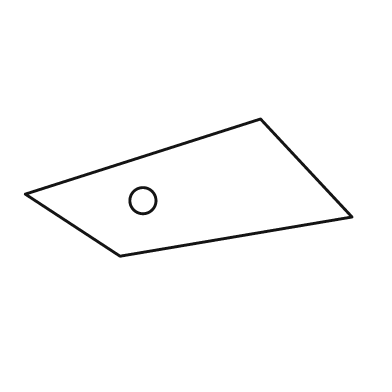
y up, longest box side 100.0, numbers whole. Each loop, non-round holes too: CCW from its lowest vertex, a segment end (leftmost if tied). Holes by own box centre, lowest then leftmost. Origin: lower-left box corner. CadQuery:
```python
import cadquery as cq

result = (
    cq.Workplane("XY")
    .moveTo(29.0, 0.0)
    .lineTo(100.0, 12.0)
    .lineTo(72.0, 42.0)
    .lineTo(0.0, 19.0)
    .close()
    .moveTo(36.0, 17.0)
    .circle(4.0)
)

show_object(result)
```